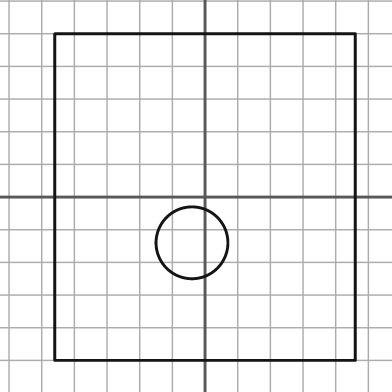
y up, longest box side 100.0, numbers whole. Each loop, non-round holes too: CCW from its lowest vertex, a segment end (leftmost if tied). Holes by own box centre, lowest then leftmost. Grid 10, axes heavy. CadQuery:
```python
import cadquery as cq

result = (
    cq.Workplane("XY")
    .moveTo(-46.0, -50.0)
    .lineTo(46.0, -50.0)
    .lineTo(46.0, 50.0)
    .lineTo(-46.0, 50.0)
    .close()
    .moveTo(-4.0, -14.0)
    .circle(11.0)
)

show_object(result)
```